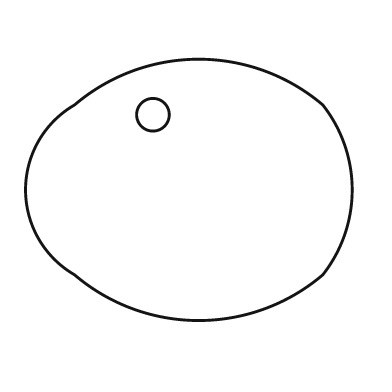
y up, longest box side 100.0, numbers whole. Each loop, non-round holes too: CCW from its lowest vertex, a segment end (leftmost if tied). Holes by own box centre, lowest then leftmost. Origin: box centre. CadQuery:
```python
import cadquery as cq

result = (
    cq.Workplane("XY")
    .moveTo(-35.0, -26.0)
    .threePointArc((3.0, -40.0), (41.0, -26.0))
    .threePointArc((50.0, 0.0), (41.0, 26.0))
    .threePointArc((3.0, 40.0), (-35.0, 26.0))
    .threePointArc((-50.0, 0.0), (-35.0, -26.0))
    .close()
    .moveTo(-11.0, 23.0)
    .circle(5.0)
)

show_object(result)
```